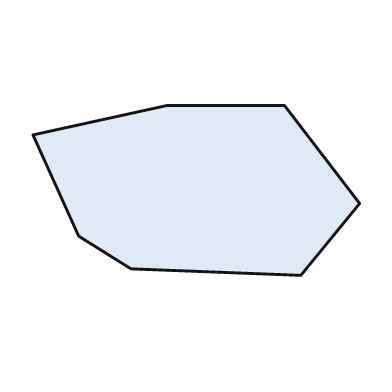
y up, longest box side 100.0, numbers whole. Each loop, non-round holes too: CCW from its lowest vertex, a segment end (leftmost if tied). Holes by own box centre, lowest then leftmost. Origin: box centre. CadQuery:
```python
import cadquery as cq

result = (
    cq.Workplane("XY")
    .moveTo(32.0, -26.0)
    .lineTo(50.0, -4.0)
    .lineTo(27.0, 26.0)
    .lineTo(-9.0, 26.0)
    .lineTo(-50.0, 17.0)
    .lineTo(-36.0, -14.0)
    .lineTo(-20.0, -24.0)
    .close()
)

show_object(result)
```